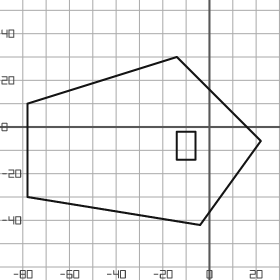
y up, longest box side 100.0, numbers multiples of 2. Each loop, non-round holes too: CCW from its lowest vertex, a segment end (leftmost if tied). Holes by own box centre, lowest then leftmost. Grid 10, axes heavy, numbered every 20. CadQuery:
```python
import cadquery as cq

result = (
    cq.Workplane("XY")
    .moveTo(-4.0, -42.0)
    .lineTo(22.0, -6.0)
    .lineTo(-14.0, 30.0)
    .lineTo(-78.0, 10.0)
    .lineTo(-78.0, -30.0)
    .close()
    .moveTo(-14.0, -14.0)
    .lineTo(-6.0, -14.0)
    .lineTo(-6.0, -2.0)
    .lineTo(-14.0, -2.0)
    .close()
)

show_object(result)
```